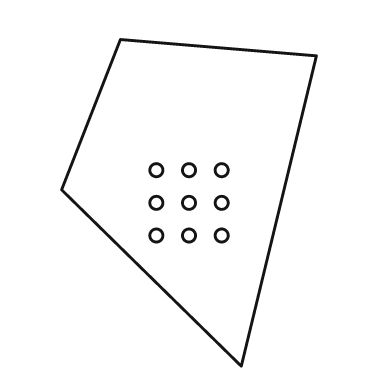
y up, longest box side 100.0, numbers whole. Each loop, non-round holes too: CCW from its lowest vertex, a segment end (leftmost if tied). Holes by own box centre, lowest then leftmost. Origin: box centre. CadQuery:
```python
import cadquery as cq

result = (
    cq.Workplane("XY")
    .moveTo(16.0, -50.0)
    .lineTo(39.0, 45.0)
    .lineTo(-21.0, 50.0)
    .lineTo(-39.0, 4.0)
    .close()
    .moveTo(-10.0, -10.0)
    .circle(2.0)
    .moveTo(0.0, -10.0)
    .circle(2.0)
    .moveTo(10.0, -10.0)
    .circle(2.0)
    .moveTo(-10.0, 0.0)
    .circle(2.0)
    .moveTo(0.0, 0.0)
    .circle(2.0)
    .moveTo(10.0, 0.0)
    .circle(2.0)
    .moveTo(-10.0, 10.0)
    .circle(2.0)
    .moveTo(0.0, 10.0)
    .circle(2.0)
    .moveTo(10.0, 10.0)
    .circle(2.0)
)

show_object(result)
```